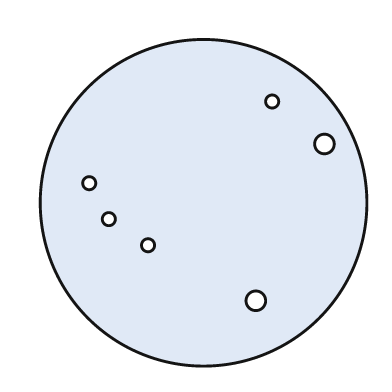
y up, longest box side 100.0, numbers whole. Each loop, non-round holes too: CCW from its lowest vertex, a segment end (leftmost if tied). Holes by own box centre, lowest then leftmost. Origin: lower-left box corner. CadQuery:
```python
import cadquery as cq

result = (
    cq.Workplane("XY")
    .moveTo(50.0, 50.0)
    .circle(50.0)
    .moveTo(66.0, 20.0)
    .circle(3.0)
    .moveTo(33.0, 37.0)
    .circle(2.0)
    .moveTo(21.0, 45.0)
    .circle(2.0)
    .moveTo(15.0, 56.0)
    .circle(2.0)
    .moveTo(87.0, 68.0)
    .circle(3.0)
    .moveTo(71.0, 81.0)
    .circle(2.0)
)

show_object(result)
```